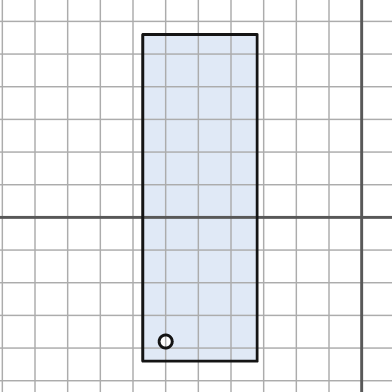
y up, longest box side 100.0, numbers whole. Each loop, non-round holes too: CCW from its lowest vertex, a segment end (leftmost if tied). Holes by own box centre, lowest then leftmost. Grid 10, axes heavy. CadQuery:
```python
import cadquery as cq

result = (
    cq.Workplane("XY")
    .moveTo(-67.0, -44.0)
    .lineTo(-32.0, -44.0)
    .lineTo(-32.0, 56.0)
    .lineTo(-67.0, 56.0)
    .close()
    .moveTo(-60.0, -38.0)
    .circle(2.0)
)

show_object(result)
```